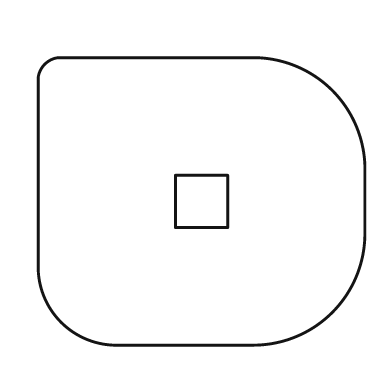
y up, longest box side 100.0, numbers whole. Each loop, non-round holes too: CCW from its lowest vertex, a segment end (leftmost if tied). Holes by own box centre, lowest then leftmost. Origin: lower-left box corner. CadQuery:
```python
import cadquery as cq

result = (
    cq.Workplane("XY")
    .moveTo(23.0, 0.0)
    .lineTo(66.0, 0.0)
    .threePointArc((90.0, 10.0), (100.0, 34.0))
    .lineTo(100.0, 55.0)
    .threePointArc((90.0, 78.0), (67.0, 88.0))
    .lineTo(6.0, 88.0)
    .threePointArc((2.0, 86.0), (0.0, 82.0))
    .lineTo(0.0, 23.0)
    .threePointArc((7.0, 7.0), (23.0, 0.0))
    .close()
    .moveTo(42.0, 36.0)
    .lineTo(58.0, 36.0)
    .lineTo(58.0, 52.0)
    .lineTo(42.0, 52.0)
    .close()
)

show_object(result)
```